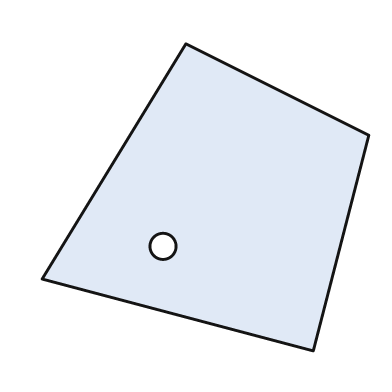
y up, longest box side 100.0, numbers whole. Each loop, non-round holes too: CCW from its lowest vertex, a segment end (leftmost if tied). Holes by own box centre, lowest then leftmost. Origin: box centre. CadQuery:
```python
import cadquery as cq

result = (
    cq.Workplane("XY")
    .moveTo(33.0, -47.0)
    .lineTo(50.0, 19.0)
    .lineTo(-6.0, 47.0)
    .lineTo(-50.0, -25.0)
    .close()
    .moveTo(-13.0, -15.0)
    .circle(4.0)
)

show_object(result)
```